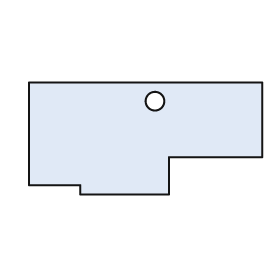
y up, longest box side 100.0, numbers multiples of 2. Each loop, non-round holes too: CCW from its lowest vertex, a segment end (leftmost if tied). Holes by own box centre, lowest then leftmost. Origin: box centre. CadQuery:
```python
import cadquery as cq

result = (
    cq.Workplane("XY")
    .moveTo(-28.0, -24.0)
    .lineTo(10.0, -24.0)
    .lineTo(10.0, -8.0)
    .lineTo(50.0, -8.0)
    .lineTo(50.0, 24.0)
    .lineTo(-50.0, 24.0)
    .lineTo(-50.0, -20.0)
    .lineTo(-28.0, -20.0)
    .close()
    .moveTo(4.0, 16.0)
    .circle(4.0)
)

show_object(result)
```